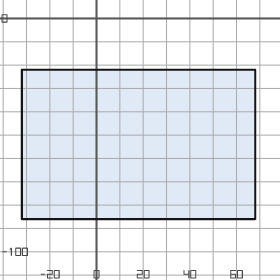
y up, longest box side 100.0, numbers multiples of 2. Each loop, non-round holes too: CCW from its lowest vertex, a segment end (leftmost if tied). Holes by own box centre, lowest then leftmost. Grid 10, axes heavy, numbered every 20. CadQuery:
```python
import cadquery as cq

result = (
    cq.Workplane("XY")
    .moveTo(-32.0, -86.0)
    .lineTo(68.0, -86.0)
    .lineTo(68.0, -22.0)
    .lineTo(-32.0, -22.0)
    .close()
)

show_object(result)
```